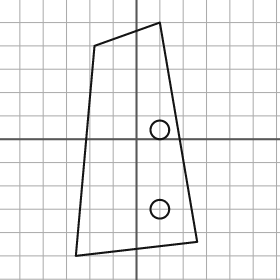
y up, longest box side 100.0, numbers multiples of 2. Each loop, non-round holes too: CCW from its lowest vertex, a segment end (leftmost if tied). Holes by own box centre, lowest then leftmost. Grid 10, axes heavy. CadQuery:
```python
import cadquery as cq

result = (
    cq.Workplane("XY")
    .moveTo(-26.0, -50.0)
    .lineTo(26.0, -44.0)
    .lineTo(10.0, 50.0)
    .lineTo(-18.0, 40.0)
    .close()
    .moveTo(10.0, -30.0)
    .circle(4.0)
    .moveTo(10.0, 4.0)
    .circle(4.0)
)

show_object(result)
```